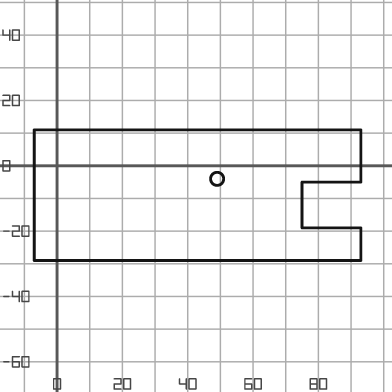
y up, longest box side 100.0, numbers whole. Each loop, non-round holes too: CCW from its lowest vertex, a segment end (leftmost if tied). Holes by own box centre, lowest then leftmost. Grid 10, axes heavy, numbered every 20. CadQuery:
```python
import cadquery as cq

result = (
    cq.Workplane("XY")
    .moveTo(-7.0, -29.0)
    .lineTo(93.0, -29.0)
    .lineTo(93.0, -19.0)
    .lineTo(75.0, -19.0)
    .lineTo(75.0, -5.0)
    .lineTo(93.0, -5.0)
    .lineTo(93.0, 11.0)
    .lineTo(-7.0, 11.0)
    .close()
    .moveTo(49.0, -4.0)
    .circle(2.0)
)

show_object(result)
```